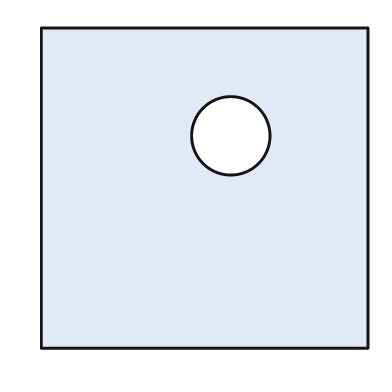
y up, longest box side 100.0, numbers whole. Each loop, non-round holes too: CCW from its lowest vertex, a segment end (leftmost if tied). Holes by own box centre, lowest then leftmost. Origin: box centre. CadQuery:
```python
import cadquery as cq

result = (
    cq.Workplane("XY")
    .moveTo(-50.0, -49.0)
    .lineTo(50.0, -49.0)
    .lineTo(50.0, 49.0)
    .lineTo(-50.0, 49.0)
    .close()
    .moveTo(8.0, 16.0)
    .circle(12.0)
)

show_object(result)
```